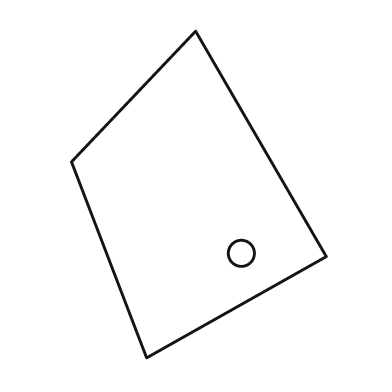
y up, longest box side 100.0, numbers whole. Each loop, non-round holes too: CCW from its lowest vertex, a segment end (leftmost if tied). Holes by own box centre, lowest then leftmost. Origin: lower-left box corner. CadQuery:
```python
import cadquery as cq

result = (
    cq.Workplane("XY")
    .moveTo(23.0, 0.0)
    .lineTo(78.0, 31.0)
    .lineTo(38.0, 100.0)
    .lineTo(0.0, 60.0)
    .close()
    .moveTo(52.0, 32.0)
    .circle(4.0)
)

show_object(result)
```